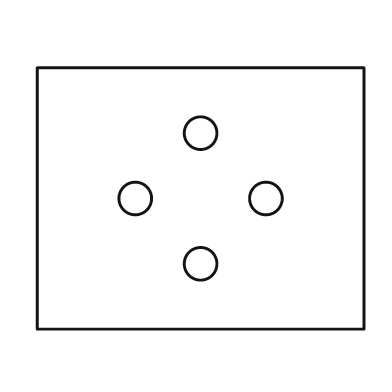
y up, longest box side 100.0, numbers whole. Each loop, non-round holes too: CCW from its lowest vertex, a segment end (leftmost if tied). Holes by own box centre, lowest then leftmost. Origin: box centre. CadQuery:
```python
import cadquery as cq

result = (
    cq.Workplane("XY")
    .moveTo(-50.0, -40.0)
    .lineTo(50.0, -40.0)
    .lineTo(50.0, 40.0)
    .lineTo(-50.0, 40.0)
    .close()
    .moveTo(0.0, -20.0)
    .circle(5.0)
    .moveTo(-20.0, 0.0)
    .circle(5.0)
    .moveTo(20.0, 0.0)
    .circle(5.0)
    .moveTo(0.0, 20.0)
    .circle(5.0)
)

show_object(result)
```